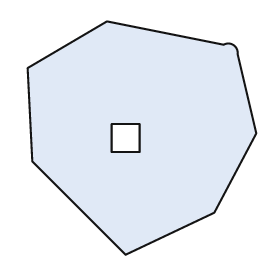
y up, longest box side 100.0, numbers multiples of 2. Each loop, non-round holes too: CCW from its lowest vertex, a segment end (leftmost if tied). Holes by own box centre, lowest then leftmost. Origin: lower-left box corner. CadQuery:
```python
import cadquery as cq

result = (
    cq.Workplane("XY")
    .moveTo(42.0, 0.0)
    .lineTo(80.0, 18.0)
    .lineTo(98.0, 52.0)
    .lineTo(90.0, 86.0)
    .threePointArc((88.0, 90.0), (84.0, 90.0))
    .lineTo(34.0, 100.0)
    .lineTo(0.0, 80.0)
    .lineTo(2.0, 40.0)
    .close()
    .moveTo(36.0, 44.0)
    .lineTo(48.0, 44.0)
    .lineTo(48.0, 56.0)
    .lineTo(36.0, 56.0)
    .close()
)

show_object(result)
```